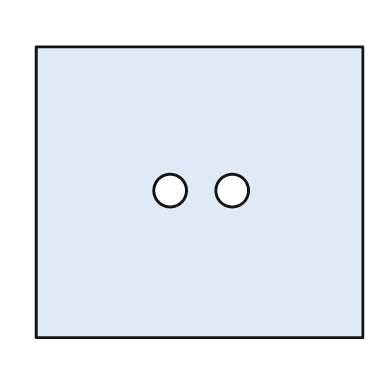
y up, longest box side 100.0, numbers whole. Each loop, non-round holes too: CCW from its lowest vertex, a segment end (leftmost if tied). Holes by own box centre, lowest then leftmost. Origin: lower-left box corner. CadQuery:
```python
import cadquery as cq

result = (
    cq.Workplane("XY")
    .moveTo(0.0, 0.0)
    .lineTo(100.0, 0.0)
    .lineTo(100.0, 89.0)
    .lineTo(0.0, 89.0)
    .close()
    .moveTo(41.0, 45.0)
    .circle(5.0)
    .moveTo(60.0, 45.0)
    .circle(5.0)
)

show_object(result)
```